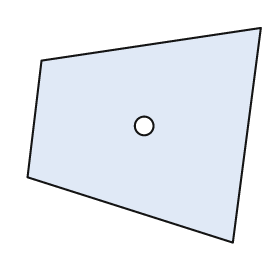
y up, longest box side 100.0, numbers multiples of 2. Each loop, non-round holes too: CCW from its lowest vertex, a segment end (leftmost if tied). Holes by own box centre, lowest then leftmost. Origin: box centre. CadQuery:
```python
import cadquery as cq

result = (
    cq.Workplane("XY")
    .moveTo(38.0, -46.0)
    .lineTo(50.0, 46.0)
    .lineTo(-44.0, 32.0)
    .lineTo(-50.0, -18.0)
    .close()
    .moveTo(0.0, 4.0)
    .circle(4.0)
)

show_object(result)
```